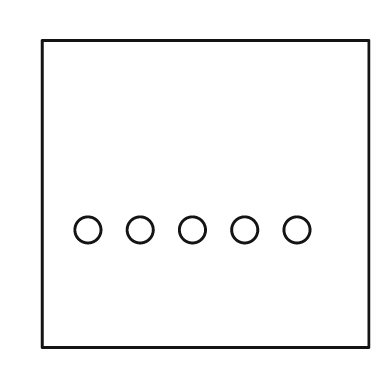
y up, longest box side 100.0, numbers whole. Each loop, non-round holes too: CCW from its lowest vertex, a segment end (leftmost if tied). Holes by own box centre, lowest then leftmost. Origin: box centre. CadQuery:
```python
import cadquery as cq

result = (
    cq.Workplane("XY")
    .moveTo(-50.0, -47.0)
    .lineTo(50.0, -47.0)
    .lineTo(50.0, 47.0)
    .lineTo(-50.0, 47.0)
    .close()
    .moveTo(-36.0, -11.0)
    .circle(4.0)
    .moveTo(-20.0, -11.0)
    .circle(4.0)
    .moveTo(-4.0, -11.0)
    .circle(4.0)
    .moveTo(12.0, -11.0)
    .circle(4.0)
    .moveTo(28.0, -11.0)
    .circle(4.0)
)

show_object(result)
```